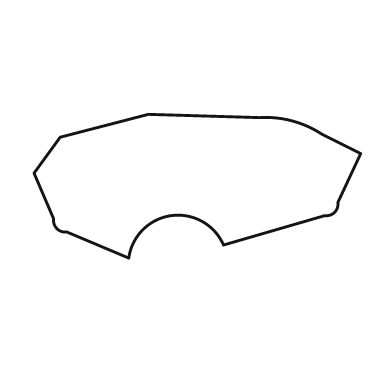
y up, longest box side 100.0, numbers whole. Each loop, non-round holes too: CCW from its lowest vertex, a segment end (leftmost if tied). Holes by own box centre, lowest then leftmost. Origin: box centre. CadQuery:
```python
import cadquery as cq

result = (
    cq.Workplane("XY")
    .moveTo(-21.0, -22.0)
    .threePointArc((-8.0, -9.0), (8.0, -18.0))
    .lineTo(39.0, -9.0)
    .threePointArc((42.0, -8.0), (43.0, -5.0))
    .lineTo(50.0, 10.0)
    .lineTo(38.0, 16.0)
    .threePointArc((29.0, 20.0), (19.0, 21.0))
    .lineTo(-15.0, 22.0)
    .lineTo(-42.0, 15.0)
    .lineTo(-50.0, 4.0)
    .lineTo(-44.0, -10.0)
    .threePointArc((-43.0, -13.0), (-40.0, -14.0))
    .close()
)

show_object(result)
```